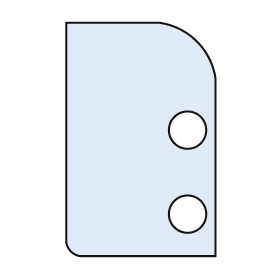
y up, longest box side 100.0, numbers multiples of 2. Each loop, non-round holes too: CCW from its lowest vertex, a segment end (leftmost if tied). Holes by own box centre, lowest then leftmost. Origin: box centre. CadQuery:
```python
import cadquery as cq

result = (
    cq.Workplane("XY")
    .moveTo(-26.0, -50.0)
    .lineTo(32.0, -50.0)
    .lineTo(32.0, 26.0)
    .threePointArc((24.0, 42.0), (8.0, 50.0))
    .lineTo(-32.0, 50.0)
    .lineTo(-32.0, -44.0)
    .threePointArc((-30.0, -48.0), (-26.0, -50.0))
    .close()
    .moveTo(20.0, -32.0)
    .circle(8.0)
    .moveTo(20.0, 4.0)
    .circle(8.0)
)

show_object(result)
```